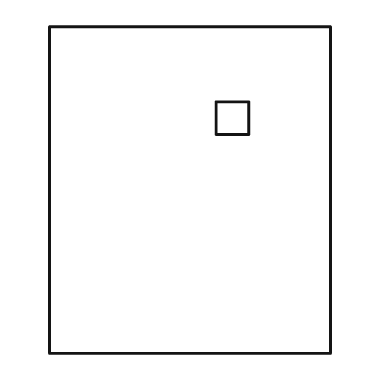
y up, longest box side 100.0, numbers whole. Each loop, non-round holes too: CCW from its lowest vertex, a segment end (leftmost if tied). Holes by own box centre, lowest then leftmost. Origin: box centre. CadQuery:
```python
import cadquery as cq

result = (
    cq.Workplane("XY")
    .moveTo(-43.0, -50.0)
    .lineTo(43.0, -50.0)
    .lineTo(43.0, 50.0)
    .lineTo(-43.0, 50.0)
    .close()
    .moveTo(8.0, 17.0)
    .lineTo(18.0, 17.0)
    .lineTo(18.0, 27.0)
    .lineTo(8.0, 27.0)
    .close()
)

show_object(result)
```